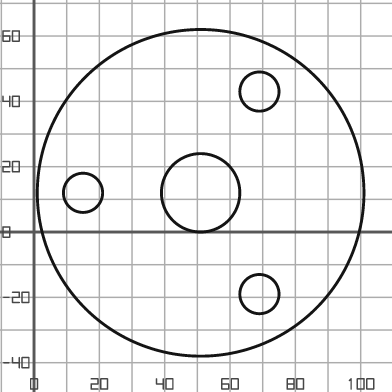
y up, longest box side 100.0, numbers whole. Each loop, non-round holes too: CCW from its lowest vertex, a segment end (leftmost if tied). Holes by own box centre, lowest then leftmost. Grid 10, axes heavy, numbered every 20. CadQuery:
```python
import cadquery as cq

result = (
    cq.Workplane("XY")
    .moveTo(51.0, 12.0)
    .circle(50.0)
    .moveTo(69.0, -19.0)
    .circle(6.0)
    .moveTo(15.0, 12.0)
    .circle(6.0)
    .moveTo(51.0, 12.0)
    .circle(12.0)
    .moveTo(69.0, 43.0)
    .circle(6.0)
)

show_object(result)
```